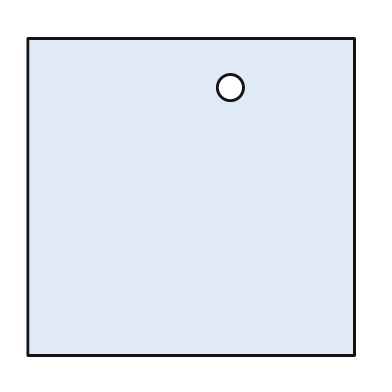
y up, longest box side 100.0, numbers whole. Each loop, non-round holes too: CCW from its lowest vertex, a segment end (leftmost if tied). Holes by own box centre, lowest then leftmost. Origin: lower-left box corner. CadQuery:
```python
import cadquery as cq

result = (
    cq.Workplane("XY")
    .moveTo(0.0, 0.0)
    .lineTo(100.0, 0.0)
    .lineTo(100.0, 97.0)
    .lineTo(0.0, 97.0)
    .close()
    .moveTo(62.0, 82.0)
    .circle(4.0)
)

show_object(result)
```